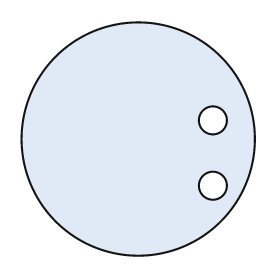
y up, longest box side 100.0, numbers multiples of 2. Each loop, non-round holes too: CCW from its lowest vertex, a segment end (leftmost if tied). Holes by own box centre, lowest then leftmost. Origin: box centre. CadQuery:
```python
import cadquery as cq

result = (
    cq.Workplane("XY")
    .moveTo(0.0, 0.0)
    .circle(50.0)
    .moveTo(32.0, -20.0)
    .circle(6.0)
    .moveTo(32.0, 8.0)
    .circle(6.0)
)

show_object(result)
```